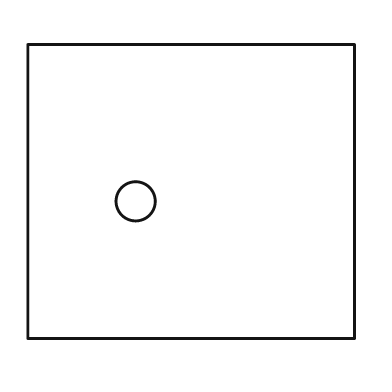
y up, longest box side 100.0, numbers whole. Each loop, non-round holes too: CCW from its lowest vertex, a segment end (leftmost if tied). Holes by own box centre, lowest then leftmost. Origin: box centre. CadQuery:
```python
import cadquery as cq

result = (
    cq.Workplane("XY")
    .moveTo(-50.0, -45.0)
    .lineTo(50.0, -45.0)
    .lineTo(50.0, 45.0)
    .lineTo(-50.0, 45.0)
    .close()
    .moveTo(-17.0, -3.0)
    .circle(6.0)
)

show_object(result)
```